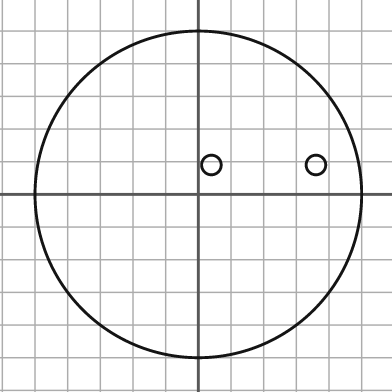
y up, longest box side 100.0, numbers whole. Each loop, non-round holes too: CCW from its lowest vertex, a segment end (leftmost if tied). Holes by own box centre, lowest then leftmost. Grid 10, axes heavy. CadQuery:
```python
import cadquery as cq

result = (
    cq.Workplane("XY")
    .moveTo(0.0, 0.0)
    .circle(50.0)
    .moveTo(4.0, 9.0)
    .circle(3.0)
    .moveTo(36.0, 9.0)
    .circle(3.0)
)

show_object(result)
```